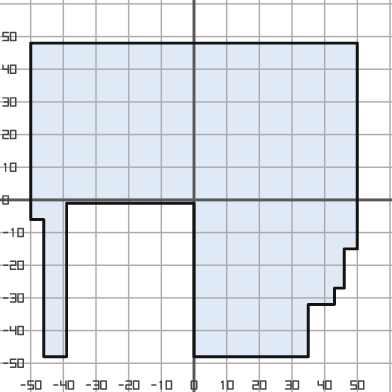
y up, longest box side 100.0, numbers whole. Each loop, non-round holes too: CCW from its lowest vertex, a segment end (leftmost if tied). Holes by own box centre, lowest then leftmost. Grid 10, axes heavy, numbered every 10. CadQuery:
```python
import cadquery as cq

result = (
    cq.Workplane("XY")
    .moveTo(-46.0, -48.0)
    .lineTo(-39.0, -48.0)
    .lineTo(-39.0, -1.0)
    .lineTo(0.0, -1.0)
    .lineTo(0.0, -48.0)
    .lineTo(35.0, -48.0)
    .lineTo(35.0, -32.0)
    .lineTo(43.0, -32.0)
    .lineTo(43.0, -27.0)
    .lineTo(46.0, -27.0)
    .lineTo(46.0, -15.0)
    .lineTo(50.0, -15.0)
    .lineTo(50.0, 48.0)
    .lineTo(-50.0, 48.0)
    .lineTo(-50.0, -6.0)
    .lineTo(-46.0, -6.0)
    .close()
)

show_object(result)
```